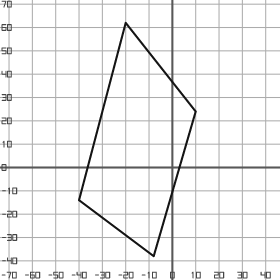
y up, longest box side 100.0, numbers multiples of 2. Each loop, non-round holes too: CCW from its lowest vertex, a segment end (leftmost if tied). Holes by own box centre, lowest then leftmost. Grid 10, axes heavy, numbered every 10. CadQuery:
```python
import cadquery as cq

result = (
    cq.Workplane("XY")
    .moveTo(-8.0, -38.0)
    .lineTo(10.0, 24.0)
    .lineTo(-20.0, 62.0)
    .lineTo(-40.0, -14.0)
    .close()
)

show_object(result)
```